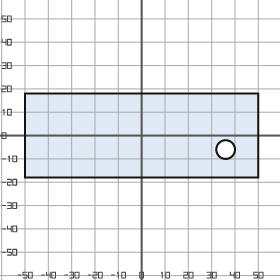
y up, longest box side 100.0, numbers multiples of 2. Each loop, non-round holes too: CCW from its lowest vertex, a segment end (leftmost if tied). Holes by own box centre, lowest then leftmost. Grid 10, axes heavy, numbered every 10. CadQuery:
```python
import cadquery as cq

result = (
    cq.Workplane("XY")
    .moveTo(-50.0, -18.0)
    .lineTo(50.0, -18.0)
    .lineTo(50.0, 18.0)
    .lineTo(-50.0, 18.0)
    .close()
    .moveTo(36.0, -6.0)
    .circle(4.0)
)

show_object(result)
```